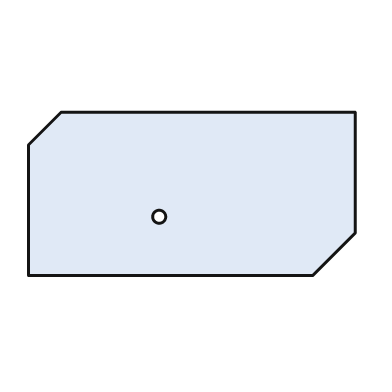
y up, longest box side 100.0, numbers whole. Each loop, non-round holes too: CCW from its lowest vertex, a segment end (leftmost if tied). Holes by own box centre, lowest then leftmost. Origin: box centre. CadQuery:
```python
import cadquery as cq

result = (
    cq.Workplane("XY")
    .moveTo(-50.0, -25.0)
    .lineTo(37.0, -25.0)
    .lineTo(50.0, -12.0)
    .lineTo(50.0, 25.0)
    .lineTo(-40.0, 25.0)
    .lineTo(-50.0, 15.0)
    .close()
    .moveTo(-10.0, -7.0)
    .circle(2.0)
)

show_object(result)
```